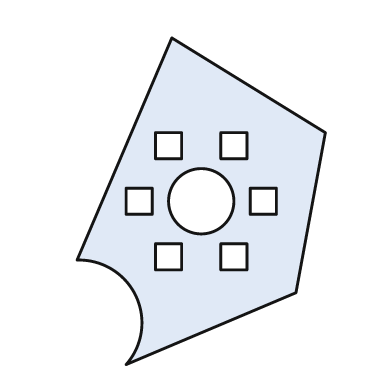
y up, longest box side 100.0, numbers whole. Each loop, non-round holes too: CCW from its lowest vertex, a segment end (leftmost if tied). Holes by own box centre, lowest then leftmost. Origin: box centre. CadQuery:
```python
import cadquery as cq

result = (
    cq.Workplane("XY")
    .moveTo(-23.0, -50.0)
    .lineTo(29.0, -28.0)
    .lineTo(38.0, 21.0)
    .lineTo(-9.0, 50.0)
    .lineTo(-38.0, -18.0)
    .threePointArc((-20.0, -29.0), (-23.0, -50.0))
    .close()
    .moveTo(-14.0, -21.0)
    .lineTo(-6.0, -21.0)
    .lineTo(-6.0, -13.0)
    .lineTo(-14.0, -13.0)
    .close()
    .moveTo(6.0, -21.0)
    .lineTo(14.0, -21.0)
    .lineTo(14.0, -13.0)
    .lineTo(6.0, -13.0)
    .close()
    .moveTo(-23.0, -4.0)
    .lineTo(-15.0, -4.0)
    .lineTo(-15.0, 4.0)
    .lineTo(-23.0, 4.0)
    .close()
    .moveTo(0.0, 0.0)
    .circle(10.0)
    .moveTo(15.0, -4.0)
    .lineTo(23.0, -4.0)
    .lineTo(23.0, 4.0)
    .lineTo(15.0, 4.0)
    .close()
    .moveTo(-14.0, 13.0)
    .lineTo(-6.0, 13.0)
    .lineTo(-6.0, 21.0)
    .lineTo(-14.0, 21.0)
    .close()
    .moveTo(6.0, 13.0)
    .lineTo(14.0, 13.0)
    .lineTo(14.0, 21.0)
    .lineTo(6.0, 21.0)
    .close()
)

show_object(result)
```